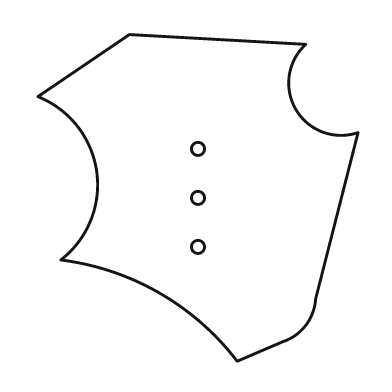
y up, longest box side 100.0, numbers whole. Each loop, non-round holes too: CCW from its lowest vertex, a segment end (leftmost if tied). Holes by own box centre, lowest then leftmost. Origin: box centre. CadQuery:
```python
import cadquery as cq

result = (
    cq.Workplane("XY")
    .moveTo(12.0, -50.0)
    .lineTo(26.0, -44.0)
    .threePointArc((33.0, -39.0), (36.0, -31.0))
    .lineTo(49.0, 20.0)
    .threePointArc((30.0, 27.0), (33.0, 47.0))
    .lineTo(-21.0, 50.0)
    .lineTo(-49.0, 31.0)
    .threePointArc((-31.0, 8.0), (-42.0, -19.0))
    .threePointArc((-12.0, -29.0), (12.0, -50.0))
    .close()
    .moveTo(0.0, -15.0)
    .circle(2.0)
    .moveTo(0.0, 0.0)
    .circle(2.0)
    .moveTo(0.0, 15.0)
    .circle(2.0)
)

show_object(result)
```